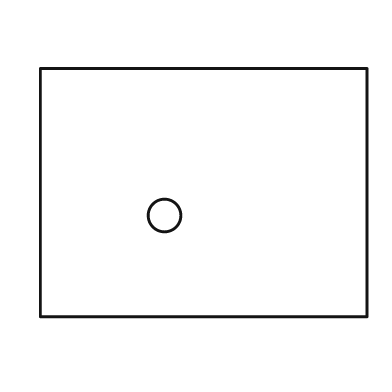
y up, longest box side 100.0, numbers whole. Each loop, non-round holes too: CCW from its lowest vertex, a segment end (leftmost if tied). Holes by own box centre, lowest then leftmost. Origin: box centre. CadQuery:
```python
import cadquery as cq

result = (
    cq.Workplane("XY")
    .moveTo(-50.0, -38.0)
    .lineTo(50.0, -38.0)
    .lineTo(50.0, 38.0)
    .lineTo(-50.0, 38.0)
    .close()
    .moveTo(-12.0, -7.0)
    .circle(5.0)
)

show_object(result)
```